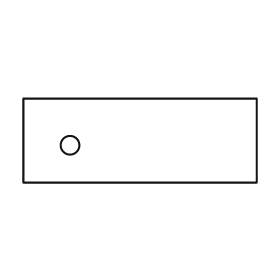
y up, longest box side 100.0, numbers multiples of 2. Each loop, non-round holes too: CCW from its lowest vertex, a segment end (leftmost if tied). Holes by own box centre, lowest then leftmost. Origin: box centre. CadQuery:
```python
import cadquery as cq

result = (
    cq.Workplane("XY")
    .moveTo(-50.0, -18.0)
    .lineTo(50.0, -18.0)
    .lineTo(50.0, 18.0)
    .lineTo(-50.0, 18.0)
    .close()
    .moveTo(-30.0, -2.0)
    .circle(4.0)
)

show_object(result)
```